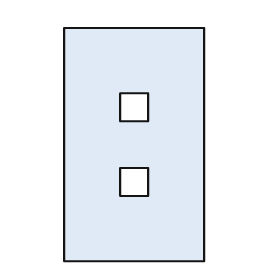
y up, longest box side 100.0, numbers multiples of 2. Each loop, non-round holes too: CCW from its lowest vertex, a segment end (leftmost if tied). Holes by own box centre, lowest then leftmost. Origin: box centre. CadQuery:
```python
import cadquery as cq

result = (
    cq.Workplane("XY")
    .moveTo(-30.0, -50.0)
    .lineTo(30.0, -50.0)
    .lineTo(30.0, 50.0)
    .lineTo(-30.0, 50.0)
    .close()
    .moveTo(-6.0, -22.0)
    .lineTo(6.0, -22.0)
    .lineTo(6.0, -10.0)
    .lineTo(-6.0, -10.0)
    .close()
    .moveTo(-6.0, 10.0)
    .lineTo(6.0, 10.0)
    .lineTo(6.0, 22.0)
    .lineTo(-6.0, 22.0)
    .close()
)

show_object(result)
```